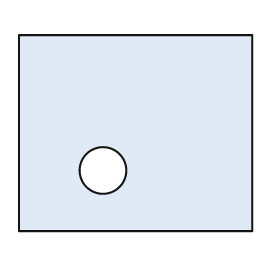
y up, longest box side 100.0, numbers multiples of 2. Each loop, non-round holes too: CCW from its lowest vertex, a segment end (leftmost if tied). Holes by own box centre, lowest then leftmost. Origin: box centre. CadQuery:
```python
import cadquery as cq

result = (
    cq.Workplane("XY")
    .moveTo(-50.0, -42.0)
    .lineTo(50.0, -42.0)
    .lineTo(50.0, 42.0)
    .lineTo(-50.0, 42.0)
    .close()
    .moveTo(-14.0, -16.0)
    .circle(10.0)
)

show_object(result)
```